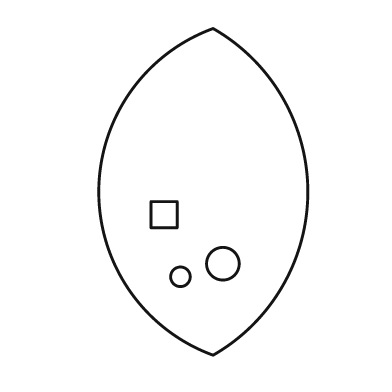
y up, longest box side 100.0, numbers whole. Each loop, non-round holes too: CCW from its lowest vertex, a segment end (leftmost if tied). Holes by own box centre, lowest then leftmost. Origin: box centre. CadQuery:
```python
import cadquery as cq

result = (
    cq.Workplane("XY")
    .moveTo(3.0, -50.0)
    .threePointArc((32.0, 0.0), (3.0, 50.0))
    .threePointArc((-32.0, 0.0), (3.0, -50.0))
    .close()
    .moveTo(-7.0, -26.0)
    .circle(3.0)
    .moveTo(6.0, -22.0)
    .circle(5.0)
    .moveTo(-16.0, -11.0)
    .lineTo(-8.0, -11.0)
    .lineTo(-8.0, -3.0)
    .lineTo(-16.0, -3.0)
    .close()
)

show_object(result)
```